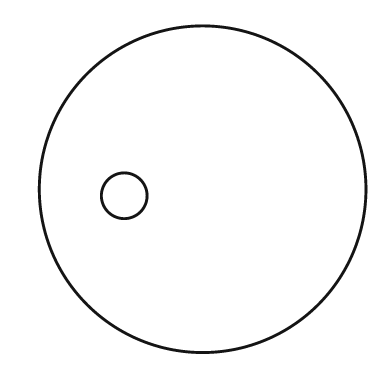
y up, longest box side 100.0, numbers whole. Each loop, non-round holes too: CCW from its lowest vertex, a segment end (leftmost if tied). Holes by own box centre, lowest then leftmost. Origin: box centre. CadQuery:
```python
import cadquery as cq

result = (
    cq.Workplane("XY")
    .moveTo(0.0, 0.0)
    .circle(50.0)
    .moveTo(-24.0, -2.0)
    .circle(7.0)
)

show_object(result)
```